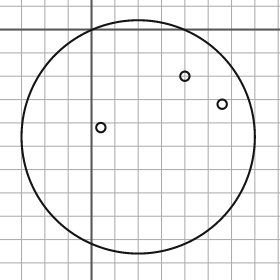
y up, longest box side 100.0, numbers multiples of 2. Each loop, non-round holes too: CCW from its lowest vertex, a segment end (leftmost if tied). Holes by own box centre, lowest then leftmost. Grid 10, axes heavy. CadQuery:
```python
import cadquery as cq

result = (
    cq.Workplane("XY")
    .moveTo(20.0, -46.0)
    .circle(50.0)
    .moveTo(4.0, -42.0)
    .circle(2.0)
    .moveTo(56.0, -32.0)
    .circle(2.0)
    .moveTo(40.0, -20.0)
    .circle(2.0)
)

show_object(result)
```